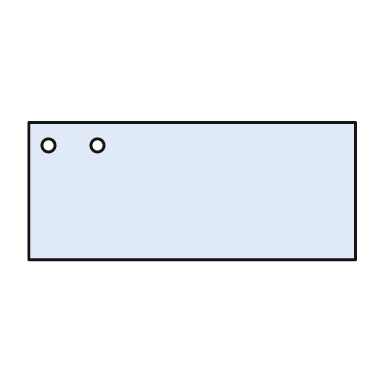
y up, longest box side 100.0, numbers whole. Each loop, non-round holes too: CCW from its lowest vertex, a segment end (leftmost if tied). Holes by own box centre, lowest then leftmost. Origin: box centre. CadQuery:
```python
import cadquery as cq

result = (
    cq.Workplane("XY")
    .moveTo(-50.0, -21.0)
    .lineTo(50.0, -21.0)
    .lineTo(50.0, 21.0)
    .lineTo(-50.0, 21.0)
    .close()
    .moveTo(-44.0, 14.0)
    .circle(2.0)
    .moveTo(-29.0, 14.0)
    .circle(2.0)
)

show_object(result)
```